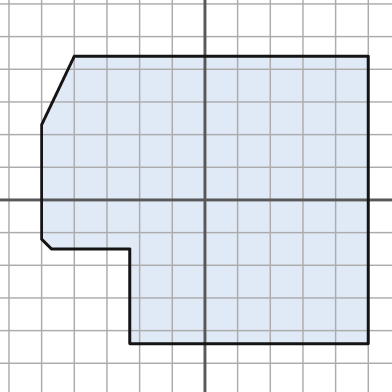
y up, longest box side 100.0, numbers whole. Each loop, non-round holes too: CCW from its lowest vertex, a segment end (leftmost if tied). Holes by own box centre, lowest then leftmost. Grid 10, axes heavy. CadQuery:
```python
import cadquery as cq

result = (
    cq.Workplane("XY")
    .moveTo(-23.0, -44.0)
    .lineTo(50.0, -44.0)
    .lineTo(50.0, 44.0)
    .lineTo(-40.0, 44.0)
    .lineTo(-50.0, 23.0)
    .lineTo(-50.0, -12.0)
    .lineTo(-47.0, -15.0)
    .lineTo(-23.0, -15.0)
    .close()
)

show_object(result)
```